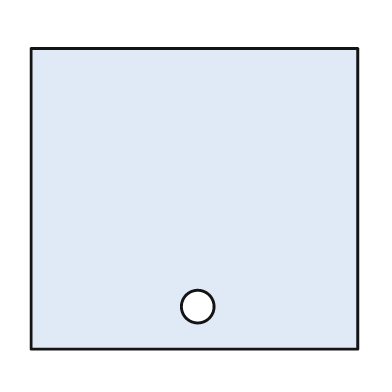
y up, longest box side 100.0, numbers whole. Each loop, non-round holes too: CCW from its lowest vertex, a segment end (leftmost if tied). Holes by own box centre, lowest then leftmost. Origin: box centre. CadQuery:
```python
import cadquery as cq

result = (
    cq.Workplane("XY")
    .moveTo(-50.0, -46.0)
    .lineTo(50.0, -46.0)
    .lineTo(50.0, 46.0)
    .lineTo(-50.0, 46.0)
    .close()
    .moveTo(1.0, -33.0)
    .circle(5.0)
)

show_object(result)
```